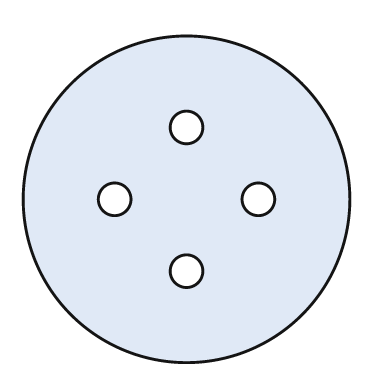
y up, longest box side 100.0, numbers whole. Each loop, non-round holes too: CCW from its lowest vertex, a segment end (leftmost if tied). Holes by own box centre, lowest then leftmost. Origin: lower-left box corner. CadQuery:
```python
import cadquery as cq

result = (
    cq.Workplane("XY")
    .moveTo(50.0, 50.0)
    .circle(50.0)
    .moveTo(50.0, 28.0)
    .circle(5.0)
    .moveTo(28.0, 50.0)
    .circle(5.0)
    .moveTo(72.0, 50.0)
    .circle(5.0)
    .moveTo(50.0, 72.0)
    .circle(5.0)
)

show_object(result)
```